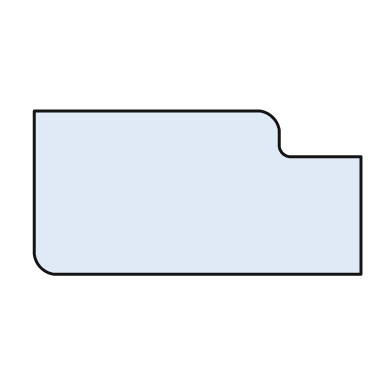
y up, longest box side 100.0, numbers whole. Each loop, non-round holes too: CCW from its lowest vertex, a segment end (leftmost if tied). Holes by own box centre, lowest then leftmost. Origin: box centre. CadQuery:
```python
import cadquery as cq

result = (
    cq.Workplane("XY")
    .moveTo(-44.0, -25.0)
    .lineTo(50.0, -25.0)
    .lineTo(50.0, 11.0)
    .lineTo(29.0, 11.0)
    .threePointArc((26.0, 12.0), (25.0, 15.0))
    .lineTo(25.0, 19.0)
    .threePointArc((23.0, 23.0), (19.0, 25.0))
    .lineTo(-50.0, 25.0)
    .lineTo(-50.0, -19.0)
    .threePointArc((-48.0, -23.0), (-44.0, -25.0))
    .close()
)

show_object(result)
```